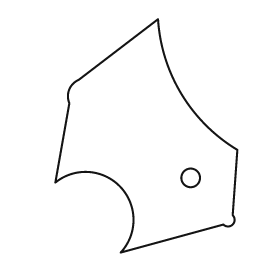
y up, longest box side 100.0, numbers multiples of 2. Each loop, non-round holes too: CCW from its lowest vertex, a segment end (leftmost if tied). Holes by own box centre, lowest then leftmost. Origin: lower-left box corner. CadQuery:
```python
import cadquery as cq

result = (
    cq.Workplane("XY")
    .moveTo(28.0, 0.0)
    .lineTo(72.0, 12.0)
    .threePointArc((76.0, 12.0), (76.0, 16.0))
    .lineTo(78.0, 44.0)
    .threePointArc((54.0, 68.0), (44.0, 100.0))
    .lineTo(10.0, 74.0)
    .threePointArc((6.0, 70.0), (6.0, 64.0))
    .lineTo(0.0, 30.0)
    .threePointArc((28.0, 28.0), (28.0, 0.0))
    .close()
    .moveTo(58.0, 32.0)
    .circle(4.0)
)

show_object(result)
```